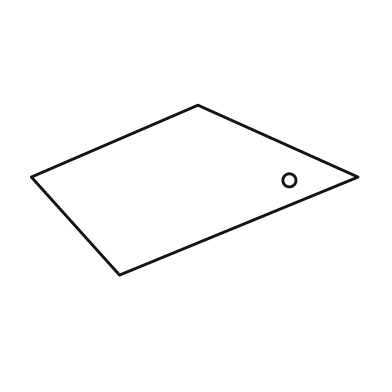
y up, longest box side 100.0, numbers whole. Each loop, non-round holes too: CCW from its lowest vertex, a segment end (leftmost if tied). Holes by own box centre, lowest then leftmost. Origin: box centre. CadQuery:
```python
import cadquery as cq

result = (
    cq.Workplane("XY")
    .moveTo(-23.0, -26.0)
    .lineTo(50.0, 4.0)
    .lineTo(1.0, 26.0)
    .lineTo(-50.0, 4.0)
    .close()
    .moveTo(29.0, 3.0)
    .circle(2.0)
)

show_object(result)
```